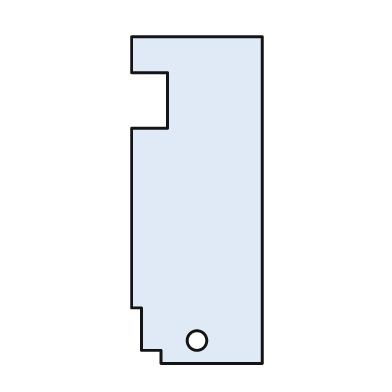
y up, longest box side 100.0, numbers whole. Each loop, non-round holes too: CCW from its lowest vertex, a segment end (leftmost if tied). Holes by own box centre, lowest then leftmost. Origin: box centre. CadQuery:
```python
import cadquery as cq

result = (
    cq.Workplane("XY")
    .moveTo(-11.0, -50.0)
    .lineTo(20.0, -50.0)
    .lineTo(20.0, 50.0)
    .lineTo(-20.0, 50.0)
    .lineTo(-20.0, 39.0)
    .lineTo(-9.0, 39.0)
    .lineTo(-9.0, 22.0)
    .lineTo(-20.0, 22.0)
    .lineTo(-20.0, -33.0)
    .lineTo(-17.0, -33.0)
    .lineTo(-17.0, -46.0)
    .lineTo(-11.0, -46.0)
    .close()
    .moveTo(0.0, -43.0)
    .circle(3.0)
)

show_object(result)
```